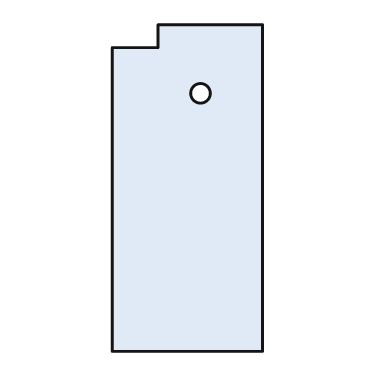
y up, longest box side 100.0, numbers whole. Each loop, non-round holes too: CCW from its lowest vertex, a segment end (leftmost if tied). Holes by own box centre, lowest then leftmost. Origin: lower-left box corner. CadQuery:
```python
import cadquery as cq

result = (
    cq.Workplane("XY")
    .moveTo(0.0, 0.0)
    .lineTo(46.0, 0.0)
    .lineTo(46.0, 100.0)
    .lineTo(14.0, 100.0)
    .lineTo(14.0, 93.0)
    .lineTo(0.0, 93.0)
    .close()
    .moveTo(27.0, 79.0)
    .circle(3.0)
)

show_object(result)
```